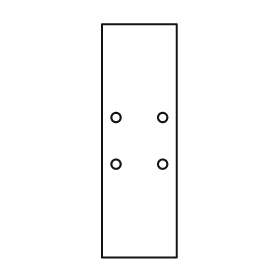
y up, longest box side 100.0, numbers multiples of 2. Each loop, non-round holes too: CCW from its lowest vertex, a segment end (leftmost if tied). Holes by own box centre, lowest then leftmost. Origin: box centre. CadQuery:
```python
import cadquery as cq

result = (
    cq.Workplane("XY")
    .moveTo(-16.0, -50.0)
    .lineTo(16.0, -50.0)
    .lineTo(16.0, 50.0)
    .lineTo(-16.0, 50.0)
    .close()
    .moveTo(-10.0, -10.0)
    .circle(2.0)
    .moveTo(10.0, -10.0)
    .circle(2.0)
    .moveTo(-10.0, 10.0)
    .circle(2.0)
    .moveTo(10.0, 10.0)
    .circle(2.0)
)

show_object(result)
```